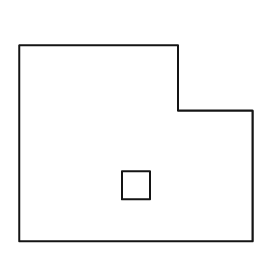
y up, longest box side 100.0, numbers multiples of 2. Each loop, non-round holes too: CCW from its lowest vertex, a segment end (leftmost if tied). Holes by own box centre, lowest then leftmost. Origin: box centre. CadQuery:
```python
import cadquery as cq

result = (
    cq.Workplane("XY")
    .moveTo(-50.0, -42.0)
    .lineTo(50.0, -42.0)
    .lineTo(50.0, 14.0)
    .lineTo(18.0, 14.0)
    .lineTo(18.0, 42.0)
    .lineTo(-50.0, 42.0)
    .close()
    .moveTo(-6.0, -24.0)
    .lineTo(6.0, -24.0)
    .lineTo(6.0, -12.0)
    .lineTo(-6.0, -12.0)
    .close()
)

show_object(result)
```